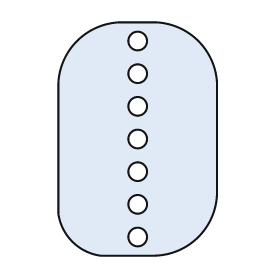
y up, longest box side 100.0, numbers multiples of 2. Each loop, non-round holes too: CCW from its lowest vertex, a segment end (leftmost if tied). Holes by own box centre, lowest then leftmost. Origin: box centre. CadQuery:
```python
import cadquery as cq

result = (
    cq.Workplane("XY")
    .moveTo(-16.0, -50.0)
    .lineTo(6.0, -50.0)
    .threePointArc((26.0, -42.0), (34.0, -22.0))
    .lineTo(34.0, 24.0)
    .threePointArc((26.0, 42.0), (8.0, 50.0))
    .lineTo(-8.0, 50.0)
    .threePointArc((-26.0, 42.0), (-34.0, 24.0))
    .lineTo(-34.0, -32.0)
    .threePointArc((-28.0, -44.0), (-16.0, -50.0))
    .close()
    .moveTo(0.0, -42.0)
    .circle(4.0)
    .moveTo(0.0, -28.0)
    .circle(4.0)
    .moveTo(0.0, -14.0)
    .circle(4.0)
    .moveTo(0.0, 0.0)
    .circle(4.0)
    .moveTo(0.0, 14.0)
    .circle(4.0)
    .moveTo(0.0, 28.0)
    .circle(4.0)
    .moveTo(0.0, 42.0)
    .circle(4.0)
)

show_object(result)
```